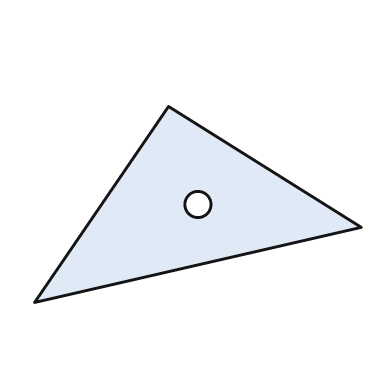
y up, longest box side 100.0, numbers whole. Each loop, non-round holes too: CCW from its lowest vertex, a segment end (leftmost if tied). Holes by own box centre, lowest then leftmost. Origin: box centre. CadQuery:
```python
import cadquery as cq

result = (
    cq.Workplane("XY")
    .moveTo(-50.0, -30.0)
    .lineTo(50.0, -7.0)
    .lineTo(-9.0, 30.0)
    .close()
    .moveTo(0.0, 0.0)
    .circle(4.0)
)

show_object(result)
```